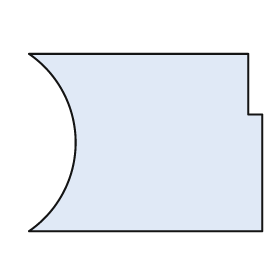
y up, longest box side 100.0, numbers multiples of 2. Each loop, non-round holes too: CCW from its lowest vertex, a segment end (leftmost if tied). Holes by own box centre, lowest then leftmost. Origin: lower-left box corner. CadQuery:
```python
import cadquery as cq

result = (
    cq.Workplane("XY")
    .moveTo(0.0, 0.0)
    .lineTo(100.0, 0.0)
    .lineTo(100.0, 50.0)
    .lineTo(94.0, 50.0)
    .lineTo(94.0, 76.0)
    .lineTo(0.0, 76.0)
    .threePointArc((20.0, 38.0), (0.0, 0.0))
    .close()
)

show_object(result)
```